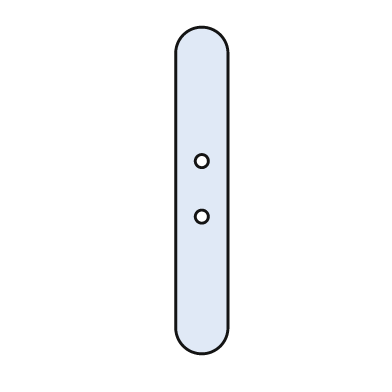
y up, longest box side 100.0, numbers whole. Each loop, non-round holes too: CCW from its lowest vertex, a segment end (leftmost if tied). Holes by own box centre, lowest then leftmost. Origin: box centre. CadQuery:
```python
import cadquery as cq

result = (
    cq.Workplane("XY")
    .moveTo(-8.0, -42.0)
    .threePointArc((0.0, -50.0), (8.0, -42.0))
    .lineTo(8.0, 42.0)
    .threePointArc((0.0, 50.0), (-8.0, 42.0))
    .close()
    .moveTo(0.0, -8.0)
    .circle(2.0)
    .moveTo(0.0, 9.0)
    .circle(2.0)
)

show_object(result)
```